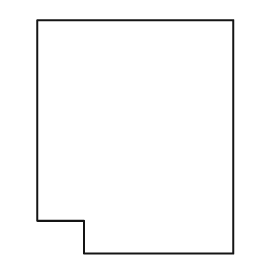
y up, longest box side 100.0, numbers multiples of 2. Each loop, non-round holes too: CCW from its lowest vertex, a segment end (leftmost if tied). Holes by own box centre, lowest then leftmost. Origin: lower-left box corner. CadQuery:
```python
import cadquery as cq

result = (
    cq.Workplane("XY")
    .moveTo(20.0, 0.0)
    .lineTo(84.0, 0.0)
    .lineTo(84.0, 100.0)
    .lineTo(0.0, 100.0)
    .lineTo(0.0, 14.0)
    .lineTo(20.0, 14.0)
    .close()
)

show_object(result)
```